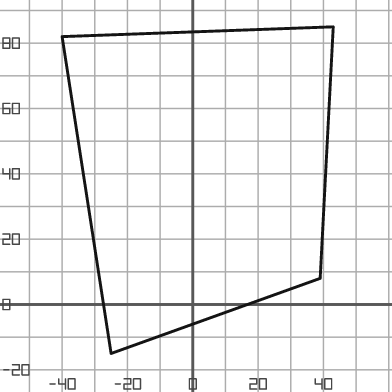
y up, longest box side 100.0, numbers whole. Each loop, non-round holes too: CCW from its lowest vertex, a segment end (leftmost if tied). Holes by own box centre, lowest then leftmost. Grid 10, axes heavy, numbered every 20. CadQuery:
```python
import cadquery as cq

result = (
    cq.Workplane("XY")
    .moveTo(-25.0, -15.0)
    .lineTo(39.0, 8.0)
    .lineTo(43.0, 85.0)
    .lineTo(-40.0, 82.0)
    .close()
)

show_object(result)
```